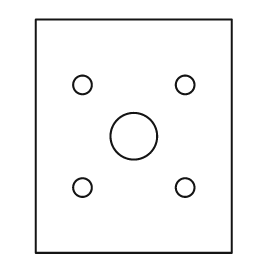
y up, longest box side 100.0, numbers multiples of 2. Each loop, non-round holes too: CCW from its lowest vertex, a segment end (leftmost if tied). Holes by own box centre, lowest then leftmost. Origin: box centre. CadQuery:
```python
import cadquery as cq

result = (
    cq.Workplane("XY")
    .moveTo(-42.0, -50.0)
    .lineTo(42.0, -50.0)
    .lineTo(42.0, 50.0)
    .lineTo(-42.0, 50.0)
    .close()
    .moveTo(-22.0, -22.0)
    .circle(4.0)
    .moveTo(22.0, -22.0)
    .circle(4.0)
    .moveTo(0.0, 0.0)
    .circle(10.0)
    .moveTo(-22.0, 22.0)
    .circle(4.0)
    .moveTo(22.0, 22.0)
    .circle(4.0)
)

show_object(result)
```